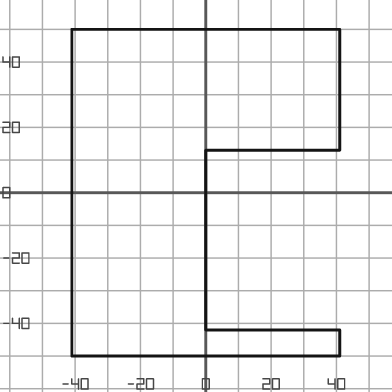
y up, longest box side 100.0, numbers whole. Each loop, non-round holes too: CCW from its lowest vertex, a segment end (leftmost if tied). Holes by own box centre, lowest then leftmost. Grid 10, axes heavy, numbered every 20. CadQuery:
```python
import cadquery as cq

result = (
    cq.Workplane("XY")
    .moveTo(-41.0, -50.0)
    .lineTo(41.0, -50.0)
    .lineTo(41.0, -42.0)
    .lineTo(0.0, -42.0)
    .lineTo(0.0, 13.0)
    .lineTo(41.0, 13.0)
    .lineTo(41.0, 50.0)
    .lineTo(-41.0, 50.0)
    .close()
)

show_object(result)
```